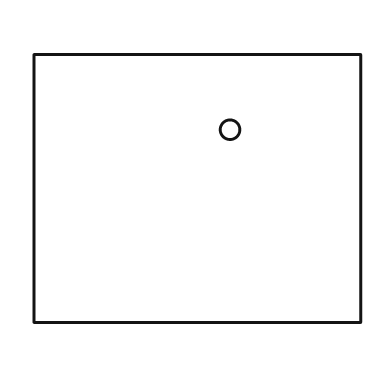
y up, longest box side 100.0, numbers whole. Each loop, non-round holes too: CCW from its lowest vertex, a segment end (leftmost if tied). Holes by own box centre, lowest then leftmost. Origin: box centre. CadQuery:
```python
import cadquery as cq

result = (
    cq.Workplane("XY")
    .moveTo(-50.0, -41.0)
    .lineTo(50.0, -41.0)
    .lineTo(50.0, 41.0)
    .lineTo(-50.0, 41.0)
    .close()
    .moveTo(10.0, 18.0)
    .circle(3.0)
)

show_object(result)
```